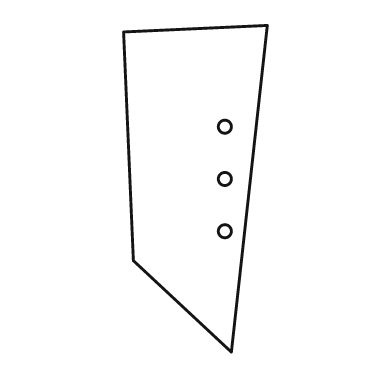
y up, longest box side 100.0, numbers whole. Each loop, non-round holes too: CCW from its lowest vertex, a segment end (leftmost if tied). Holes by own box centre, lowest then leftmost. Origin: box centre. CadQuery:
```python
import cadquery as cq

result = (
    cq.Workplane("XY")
    .moveTo(11.0, -50.0)
    .lineTo(22.0, 50.0)
    .lineTo(-22.0, 48.0)
    .lineTo(-19.0, -22.0)
    .close()
    .moveTo(9.0, -13.0)
    .circle(2.0)
    .moveTo(9.0, 3.0)
    .circle(2.0)
    .moveTo(9.0, 19.0)
    .circle(2.0)
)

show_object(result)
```